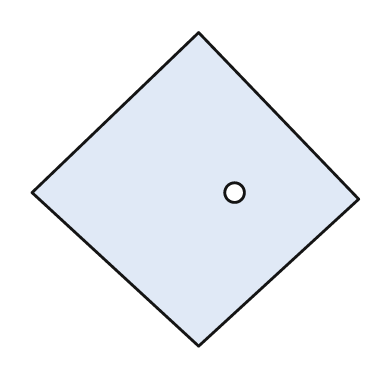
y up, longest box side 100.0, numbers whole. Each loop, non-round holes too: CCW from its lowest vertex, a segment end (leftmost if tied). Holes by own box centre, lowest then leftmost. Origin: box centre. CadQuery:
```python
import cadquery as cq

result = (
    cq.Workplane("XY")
    .moveTo(1.0, -48.0)
    .lineTo(50.0, -3.0)
    .lineTo(1.0, 48.0)
    .lineTo(-50.0, -1.0)
    .close()
    .moveTo(12.0, -1.0)
    .circle(3.0)
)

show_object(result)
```